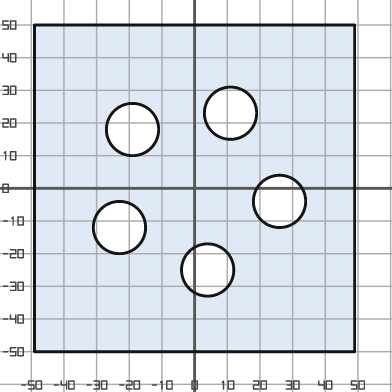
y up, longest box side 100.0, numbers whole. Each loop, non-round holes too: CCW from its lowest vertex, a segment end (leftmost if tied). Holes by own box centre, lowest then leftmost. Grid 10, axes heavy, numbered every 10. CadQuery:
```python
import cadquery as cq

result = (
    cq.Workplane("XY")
    .moveTo(-49.0, -50.0)
    .lineTo(49.0, -50.0)
    .lineTo(49.0, 50.0)
    .lineTo(-49.0, 50.0)
    .close()
    .moveTo(4.0, -25.0)
    .circle(8.0)
    .moveTo(-23.0, -12.0)
    .circle(8.0)
    .moveTo(26.0, -4.0)
    .circle(8.0)
    .moveTo(-19.0, 18.0)
    .circle(8.0)
    .moveTo(11.0, 23.0)
    .circle(8.0)
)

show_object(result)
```